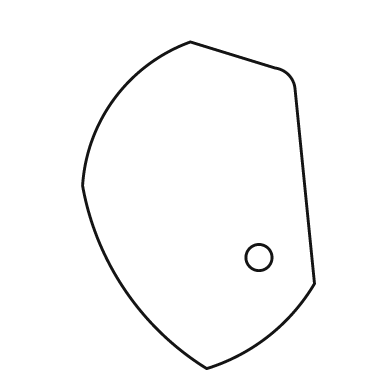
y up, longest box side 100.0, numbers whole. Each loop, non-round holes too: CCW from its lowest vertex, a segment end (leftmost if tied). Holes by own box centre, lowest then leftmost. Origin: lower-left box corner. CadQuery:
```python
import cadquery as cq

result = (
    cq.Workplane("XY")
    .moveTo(38.0, 0.0)
    .threePointArc((57.0, 10.0), (71.0, 26.0))
    .lineTo(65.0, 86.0)
    .threePointArc((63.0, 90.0), (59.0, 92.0))
    .lineTo(33.0, 100.0)
    .threePointArc((10.0, 83.0), (0.0, 56.0))
    .threePointArc((13.0, 24.0), (38.0, 0.0))
    .close()
    .moveTo(54.0, 34.0)
    .circle(4.0)
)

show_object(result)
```